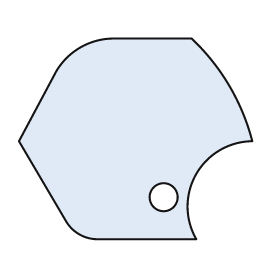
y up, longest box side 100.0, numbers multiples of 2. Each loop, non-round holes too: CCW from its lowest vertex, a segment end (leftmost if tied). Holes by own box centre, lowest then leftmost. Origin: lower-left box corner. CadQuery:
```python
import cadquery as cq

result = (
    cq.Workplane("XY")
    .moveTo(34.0, 0.0)
    .lineTo(76.0, 0.0)
    .threePointArc((76.0, 28.0), (100.0, 42.0))
    .threePointArc((90.0, 66.0), (74.0, 86.0))
    .lineTo(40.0, 86.0)
    .threePointArc((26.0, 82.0), (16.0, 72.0))
    .lineTo(0.0, 42.0)
    .lineTo(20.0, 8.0)
    .threePointArc((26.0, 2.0), (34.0, 0.0))
    .close()
    .moveTo(62.0, 18.0)
    .circle(6.0)
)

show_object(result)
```